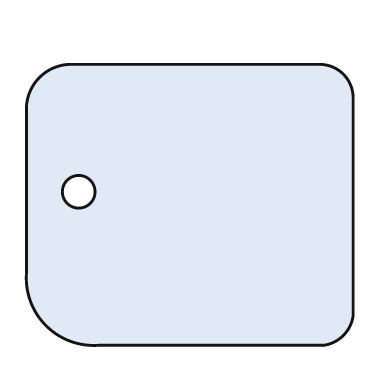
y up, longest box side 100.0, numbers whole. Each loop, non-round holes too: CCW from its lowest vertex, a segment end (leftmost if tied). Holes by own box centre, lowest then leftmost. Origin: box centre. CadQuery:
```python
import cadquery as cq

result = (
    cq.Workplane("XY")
    .moveTo(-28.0, -43.0)
    .lineTo(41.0, -43.0)
    .threePointArc((47.0, -40.0), (50.0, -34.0))
    .lineTo(50.0, 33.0)
    .threePointArc((47.0, 40.0), (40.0, 43.0))
    .lineTo(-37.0, 43.0)
    .threePointArc((-46.0, 39.0), (-50.0, 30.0))
    .lineTo(-50.0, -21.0)
    .threePointArc((-44.0, -37.0), (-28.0, -43.0))
    .close()
    .moveTo(-34.0, 4.0)
    .circle(5.0)
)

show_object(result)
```